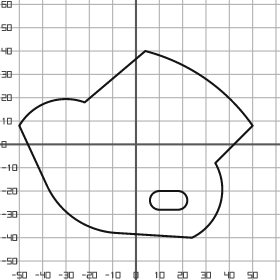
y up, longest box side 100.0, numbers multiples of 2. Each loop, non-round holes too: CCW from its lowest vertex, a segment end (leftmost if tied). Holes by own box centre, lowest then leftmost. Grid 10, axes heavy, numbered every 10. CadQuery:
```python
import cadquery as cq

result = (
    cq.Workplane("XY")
    .moveTo(24.0, -40.0)
    .threePointArc((36.0, -26.0), (34.0, -8.0))
    .lineTo(50.0, 8.0)
    .threePointArc((30.0, 28.0), (4.0, 40.0))
    .lineTo(-22.0, 18.0)
    .threePointArc((-38.0, 18.0), (-50.0, 8.0))
    .lineTo(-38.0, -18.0)
    .threePointArc((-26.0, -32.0), (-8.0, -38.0))
    .close()
    .moveTo(10.0, -28.0)
    .lineTo(18.0, -28.0)
    .threePointArc((22.0, -24.0), (18.0, -20.0))
    .lineTo(10.0, -20.0)
    .threePointArc((6.0, -24.0), (10.0, -28.0))
    .close()
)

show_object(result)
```